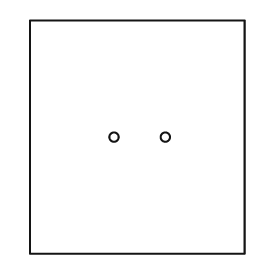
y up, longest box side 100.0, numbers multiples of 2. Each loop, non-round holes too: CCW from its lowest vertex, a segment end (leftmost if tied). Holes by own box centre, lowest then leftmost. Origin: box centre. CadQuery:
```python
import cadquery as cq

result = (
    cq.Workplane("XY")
    .moveTo(-46.0, -50.0)
    .lineTo(46.0, -50.0)
    .lineTo(46.0, 50.0)
    .lineTo(-46.0, 50.0)
    .close()
    .moveTo(-10.0, 0.0)
    .circle(2.0)
    .moveTo(12.0, 0.0)
    .circle(2.0)
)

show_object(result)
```